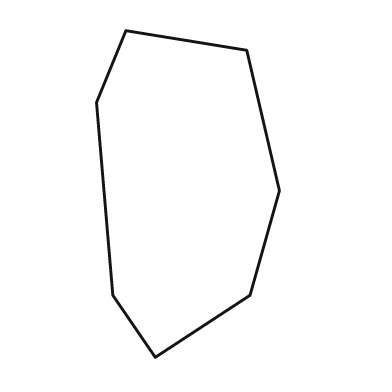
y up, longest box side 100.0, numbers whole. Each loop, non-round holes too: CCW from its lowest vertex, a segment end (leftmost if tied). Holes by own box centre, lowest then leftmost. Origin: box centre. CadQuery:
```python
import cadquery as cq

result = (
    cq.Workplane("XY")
    .moveTo(-10.0, -50.0)
    .lineTo(19.0, -31.0)
    .lineTo(28.0, 1.0)
    .lineTo(18.0, 44.0)
    .lineTo(-19.0, 50.0)
    .lineTo(-28.0, 28.0)
    .lineTo(-23.0, -31.0)
    .close()
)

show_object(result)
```